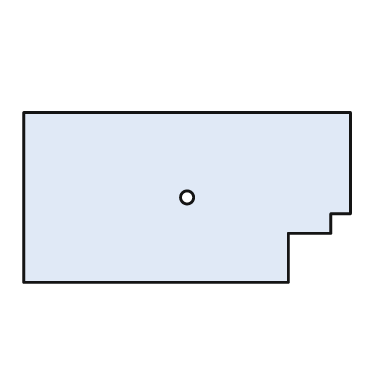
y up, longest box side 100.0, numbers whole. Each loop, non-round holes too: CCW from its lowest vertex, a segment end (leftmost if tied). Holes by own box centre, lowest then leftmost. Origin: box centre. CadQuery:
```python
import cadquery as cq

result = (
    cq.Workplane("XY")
    .moveTo(-50.0, -26.0)
    .lineTo(31.0, -26.0)
    .lineTo(31.0, -11.0)
    .lineTo(44.0, -11.0)
    .lineTo(44.0, -5.0)
    .lineTo(50.0, -5.0)
    .lineTo(50.0, 26.0)
    .lineTo(-50.0, 26.0)
    .close()
    .moveTo(0.0, 0.0)
    .circle(2.0)
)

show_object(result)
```